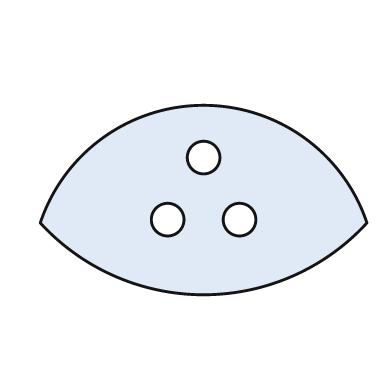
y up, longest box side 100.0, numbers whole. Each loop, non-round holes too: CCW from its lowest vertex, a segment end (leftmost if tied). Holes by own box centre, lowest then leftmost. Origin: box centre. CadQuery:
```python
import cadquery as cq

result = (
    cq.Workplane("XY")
    .moveTo(-50.0, -7.0)
    .threePointArc((0.0, -29.0), (50.0, -7.0))
    .threePointArc((0.0, 29.0), (-50.0, -7.0))
    .close()
    .moveTo(-11.0, -6.0)
    .circle(5.0)
    .moveTo(11.0, -6.0)
    .circle(5.0)
    .moveTo(0.0, 13.0)
    .circle(5.0)
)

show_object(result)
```